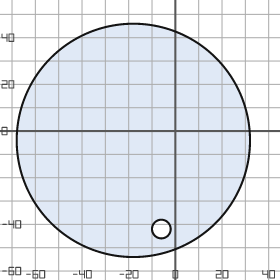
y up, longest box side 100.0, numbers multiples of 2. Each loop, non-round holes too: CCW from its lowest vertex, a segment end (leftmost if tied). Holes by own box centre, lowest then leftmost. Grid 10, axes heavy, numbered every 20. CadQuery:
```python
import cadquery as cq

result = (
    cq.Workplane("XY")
    .moveTo(-18.0, -4.0)
    .circle(50.0)
    .moveTo(-6.0, -42.0)
    .circle(4.0)
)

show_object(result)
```